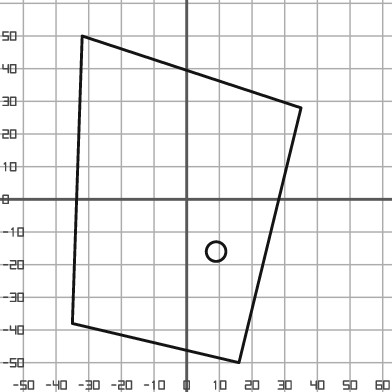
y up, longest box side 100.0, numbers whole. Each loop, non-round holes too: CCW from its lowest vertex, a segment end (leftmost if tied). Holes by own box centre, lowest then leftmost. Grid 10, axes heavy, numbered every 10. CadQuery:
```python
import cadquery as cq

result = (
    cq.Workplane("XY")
    .moveTo(16.0, -50.0)
    .lineTo(35.0, 28.0)
    .lineTo(-32.0, 50.0)
    .lineTo(-35.0, -38.0)
    .close()
    .moveTo(9.0, -16.0)
    .circle(3.0)
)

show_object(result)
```